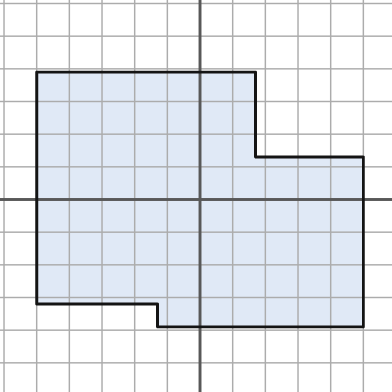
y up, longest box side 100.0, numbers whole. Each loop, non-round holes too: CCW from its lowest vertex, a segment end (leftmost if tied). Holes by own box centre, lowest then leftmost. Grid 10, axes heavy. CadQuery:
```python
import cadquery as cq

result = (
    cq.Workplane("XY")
    .moveTo(-13.0, -39.0)
    .lineTo(50.0, -39.0)
    .lineTo(50.0, 13.0)
    .lineTo(17.0, 13.0)
    .lineTo(17.0, 39.0)
    .lineTo(-50.0, 39.0)
    .lineTo(-50.0, -32.0)
    .lineTo(-13.0, -32.0)
    .close()
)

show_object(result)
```